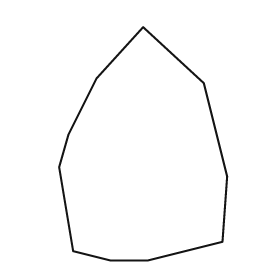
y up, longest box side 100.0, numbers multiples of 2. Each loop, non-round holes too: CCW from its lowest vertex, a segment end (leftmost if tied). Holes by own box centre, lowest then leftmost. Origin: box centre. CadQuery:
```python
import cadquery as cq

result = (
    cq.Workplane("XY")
    .moveTo(-14.0, -50.0)
    .lineTo(2.0, -50.0)
    .lineTo(34.0, -42.0)
    .lineTo(36.0, -14.0)
    .lineTo(26.0, 26.0)
    .lineTo(0.0, 50.0)
    .lineTo(-20.0, 28.0)
    .lineTo(-32.0, 4.0)
    .lineTo(-36.0, -10.0)
    .lineTo(-30.0, -46.0)
    .close()
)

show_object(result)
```